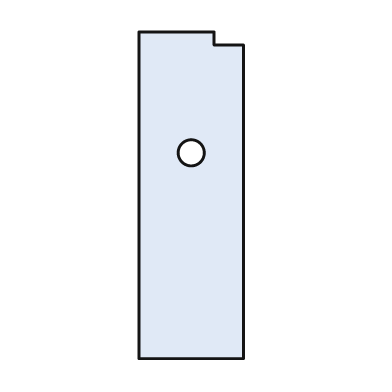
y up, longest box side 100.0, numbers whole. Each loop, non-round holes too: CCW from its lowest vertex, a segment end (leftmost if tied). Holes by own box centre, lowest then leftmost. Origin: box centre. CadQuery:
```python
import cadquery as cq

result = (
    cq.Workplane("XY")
    .moveTo(-16.0, -50.0)
    .lineTo(16.0, -50.0)
    .lineTo(16.0, 46.0)
    .lineTo(7.0, 46.0)
    .lineTo(7.0, 50.0)
    .lineTo(-16.0, 50.0)
    .close()
    .moveTo(0.0, 13.0)
    .circle(4.0)
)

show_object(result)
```